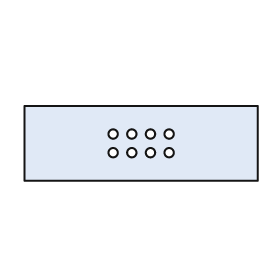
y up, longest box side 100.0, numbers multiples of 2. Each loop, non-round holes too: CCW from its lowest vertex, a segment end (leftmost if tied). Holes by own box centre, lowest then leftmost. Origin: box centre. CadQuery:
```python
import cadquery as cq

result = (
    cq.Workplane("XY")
    .moveTo(-50.0, -16.0)
    .lineTo(50.0, -16.0)
    .lineTo(50.0, 16.0)
    .lineTo(-50.0, 16.0)
    .close()
    .moveTo(-12.0, -4.0)
    .circle(2.0)
    .moveTo(-4.0, -4.0)
    .circle(2.0)
    .moveTo(4.0, -4.0)
    .circle(2.0)
    .moveTo(12.0, -4.0)
    .circle(2.0)
    .moveTo(-12.0, 4.0)
    .circle(2.0)
    .moveTo(-4.0, 4.0)
    .circle(2.0)
    .moveTo(4.0, 4.0)
    .circle(2.0)
    .moveTo(12.0, 4.0)
    .circle(2.0)
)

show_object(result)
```